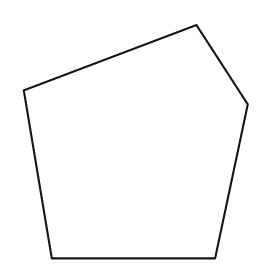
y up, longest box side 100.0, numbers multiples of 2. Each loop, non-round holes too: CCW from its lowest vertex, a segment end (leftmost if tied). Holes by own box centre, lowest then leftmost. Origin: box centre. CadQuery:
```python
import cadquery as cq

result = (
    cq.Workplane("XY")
    .moveTo(-36.0, -50.0)
    .lineTo(34.0, -50.0)
    .lineTo(48.0, 16.0)
    .lineTo(26.0, 50.0)
    .lineTo(-48.0, 22.0)
    .close()
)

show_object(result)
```